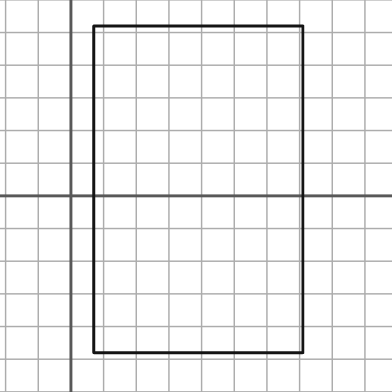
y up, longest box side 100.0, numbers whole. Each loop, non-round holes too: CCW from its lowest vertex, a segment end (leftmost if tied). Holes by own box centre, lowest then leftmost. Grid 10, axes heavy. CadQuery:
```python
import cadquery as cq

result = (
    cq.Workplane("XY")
    .moveTo(7.0, -48.0)
    .lineTo(71.0, -48.0)
    .lineTo(71.0, 52.0)
    .lineTo(7.0, 52.0)
    .close()
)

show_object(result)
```